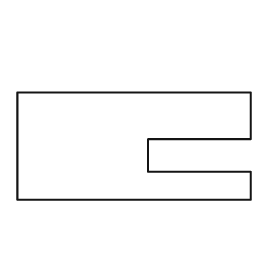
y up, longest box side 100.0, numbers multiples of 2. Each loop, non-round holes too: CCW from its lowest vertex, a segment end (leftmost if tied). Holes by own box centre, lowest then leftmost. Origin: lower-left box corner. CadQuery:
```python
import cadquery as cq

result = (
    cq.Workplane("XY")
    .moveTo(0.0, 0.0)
    .lineTo(100.0, 0.0)
    .lineTo(100.0, 12.0)
    .lineTo(56.0, 12.0)
    .lineTo(56.0, 26.0)
    .lineTo(100.0, 26.0)
    .lineTo(100.0, 46.0)
    .lineTo(0.0, 46.0)
    .close()
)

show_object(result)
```